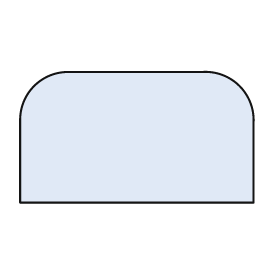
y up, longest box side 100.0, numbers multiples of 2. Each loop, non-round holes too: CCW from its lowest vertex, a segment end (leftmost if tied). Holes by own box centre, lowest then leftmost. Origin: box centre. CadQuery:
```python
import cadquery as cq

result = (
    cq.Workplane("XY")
    .moveTo(-50.0, -28.0)
    .lineTo(50.0, -28.0)
    .lineTo(50.0, 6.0)
    .threePointArc((44.0, 22.0), (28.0, 28.0))
    .lineTo(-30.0, 28.0)
    .threePointArc((-44.0, 22.0), (-50.0, 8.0))
    .close()
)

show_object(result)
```